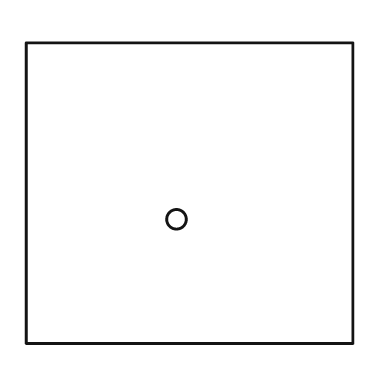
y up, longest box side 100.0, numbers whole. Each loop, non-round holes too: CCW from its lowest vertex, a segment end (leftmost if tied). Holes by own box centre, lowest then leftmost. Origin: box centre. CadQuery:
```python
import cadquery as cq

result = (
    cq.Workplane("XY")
    .moveTo(-50.0, -46.0)
    .lineTo(50.0, -46.0)
    .lineTo(50.0, 46.0)
    .lineTo(-50.0, 46.0)
    .close()
    .moveTo(-4.0, -8.0)
    .circle(3.0)
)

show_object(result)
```